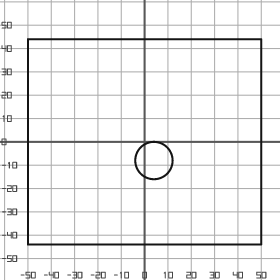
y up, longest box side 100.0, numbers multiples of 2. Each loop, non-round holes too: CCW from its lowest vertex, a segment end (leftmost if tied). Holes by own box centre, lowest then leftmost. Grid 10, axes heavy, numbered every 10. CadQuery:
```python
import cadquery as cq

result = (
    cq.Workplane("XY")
    .moveTo(-50.0, -44.0)
    .lineTo(50.0, -44.0)
    .lineTo(50.0, 44.0)
    .lineTo(-50.0, 44.0)
    .close()
    .moveTo(4.0, -8.0)
    .circle(8.0)
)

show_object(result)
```